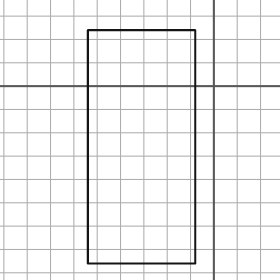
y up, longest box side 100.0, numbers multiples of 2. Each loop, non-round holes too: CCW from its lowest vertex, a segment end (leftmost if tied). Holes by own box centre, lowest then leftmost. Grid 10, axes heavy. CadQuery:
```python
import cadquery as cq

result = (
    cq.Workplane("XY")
    .moveTo(-54.0, -76.0)
    .lineTo(-8.0, -76.0)
    .lineTo(-8.0, 24.0)
    .lineTo(-54.0, 24.0)
    .close()
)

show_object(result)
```